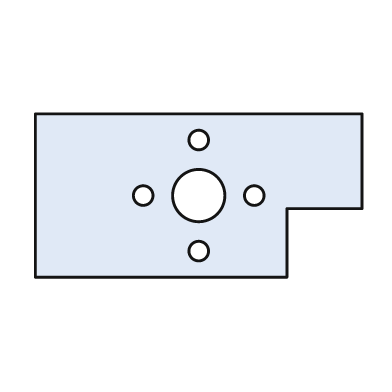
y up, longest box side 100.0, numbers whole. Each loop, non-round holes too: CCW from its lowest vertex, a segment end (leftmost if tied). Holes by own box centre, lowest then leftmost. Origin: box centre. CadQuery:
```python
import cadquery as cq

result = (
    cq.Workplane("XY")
    .moveTo(-50.0, -25.0)
    .lineTo(27.0, -25.0)
    .lineTo(27.0, -4.0)
    .lineTo(50.0, -4.0)
    .lineTo(50.0, 25.0)
    .lineTo(-50.0, 25.0)
    .close()
    .moveTo(0.0, -17.0)
    .circle(3.0)
    .moveTo(-17.0, 0.0)
    .circle(3.0)
    .moveTo(0.0, 0.0)
    .circle(8.0)
    .moveTo(17.0, 0.0)
    .circle(3.0)
    .moveTo(0.0, 17.0)
    .circle(3.0)
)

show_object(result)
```